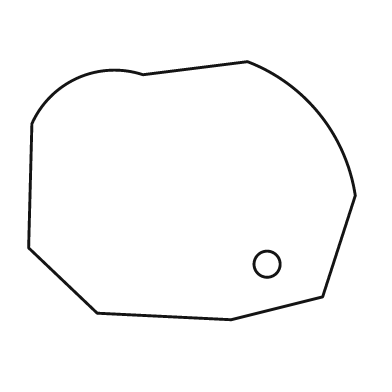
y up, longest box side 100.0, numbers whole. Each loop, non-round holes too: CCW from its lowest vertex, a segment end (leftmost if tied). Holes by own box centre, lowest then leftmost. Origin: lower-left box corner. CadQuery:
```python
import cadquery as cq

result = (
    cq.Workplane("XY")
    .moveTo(62.0, 0.0)
    .lineTo(90.0, 7.0)
    .lineTo(100.0, 38.0)
    .threePointArc((89.0, 63.0), (67.0, 79.0))
    .lineTo(35.0, 75.0)
    .threePointArc((15.0, 74.0), (1.0, 60.0))
    .lineTo(0.0, 22.0)
    .lineTo(21.0, 2.0)
    .close()
    .moveTo(73.0, 17.0)
    .circle(4.0)
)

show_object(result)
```